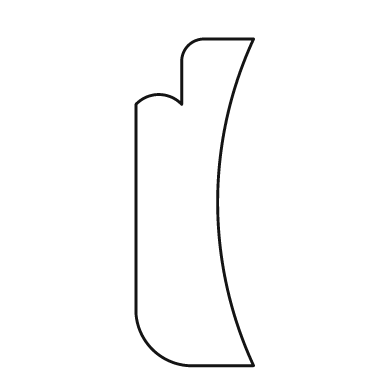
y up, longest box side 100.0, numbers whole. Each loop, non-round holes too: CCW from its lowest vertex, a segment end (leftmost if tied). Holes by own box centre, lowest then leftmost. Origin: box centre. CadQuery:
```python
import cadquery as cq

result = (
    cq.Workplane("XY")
    .moveTo(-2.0, -50.0)
    .lineTo(18.0, -50.0)
    .threePointArc((7.0, 0.0), (18.0, 50.0))
    .lineTo(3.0, 50.0)
    .threePointArc((-2.0, 48.0), (-4.0, 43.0))
    .lineTo(-4.0, 30.0)
    .threePointArc((-11.0, 33.0), (-18.0, 30.0))
    .lineTo(-18.0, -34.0)
    .threePointArc((-13.0, -45.0), (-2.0, -50.0))
    .close()
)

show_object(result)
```